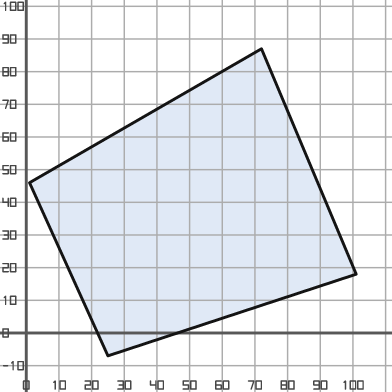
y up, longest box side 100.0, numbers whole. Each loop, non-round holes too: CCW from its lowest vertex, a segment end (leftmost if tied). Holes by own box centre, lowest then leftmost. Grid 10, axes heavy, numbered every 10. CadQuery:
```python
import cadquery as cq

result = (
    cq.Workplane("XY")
    .moveTo(25.0, -7.0)
    .lineTo(101.0, 18.0)
    .lineTo(72.0, 87.0)
    .lineTo(1.0, 46.0)
    .close()
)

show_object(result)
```